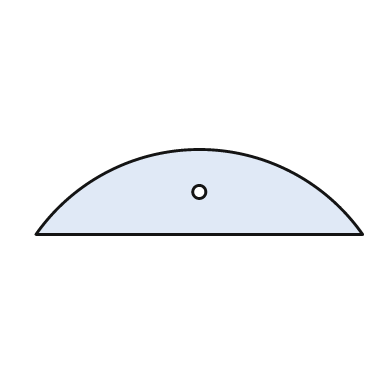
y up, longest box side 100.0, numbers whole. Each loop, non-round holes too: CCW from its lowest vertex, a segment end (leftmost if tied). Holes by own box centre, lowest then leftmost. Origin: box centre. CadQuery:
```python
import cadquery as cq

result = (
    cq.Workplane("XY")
    .moveTo(-50.0, -13.0)
    .lineTo(50.0, -13.0)
    .threePointArc((0.0, 13.0), (-50.0, -13.0))
    .close()
    .moveTo(0.0, 0.0)
    .circle(2.0)
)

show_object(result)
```